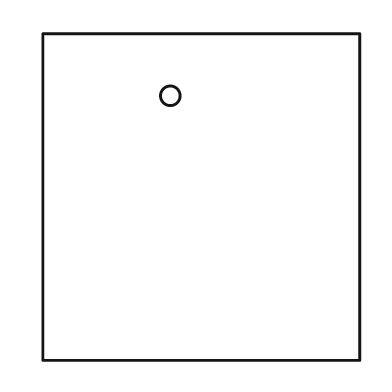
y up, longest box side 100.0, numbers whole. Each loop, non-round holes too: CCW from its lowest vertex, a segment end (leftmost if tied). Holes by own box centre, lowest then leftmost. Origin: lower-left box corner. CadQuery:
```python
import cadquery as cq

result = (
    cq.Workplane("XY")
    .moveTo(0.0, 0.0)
    .lineTo(97.0, 0.0)
    .lineTo(97.0, 100.0)
    .lineTo(0.0, 100.0)
    .close()
    .moveTo(39.0, 81.0)
    .circle(3.0)
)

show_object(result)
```